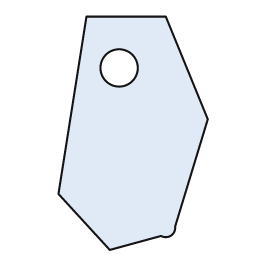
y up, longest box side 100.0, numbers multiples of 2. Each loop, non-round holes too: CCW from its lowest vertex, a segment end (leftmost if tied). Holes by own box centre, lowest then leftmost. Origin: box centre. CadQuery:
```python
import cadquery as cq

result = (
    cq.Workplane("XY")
    .moveTo(-10.0, -50.0)
    .lineTo(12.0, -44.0)
    .threePointArc((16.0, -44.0), (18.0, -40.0))
    .lineTo(32.0, 6.0)
    .lineTo(14.0, 50.0)
    .lineTo(-20.0, 50.0)
    .lineTo(-32.0, -26.0)
    .close()
    .moveTo(-6.0, 28.0)
    .circle(8.0)
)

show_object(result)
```